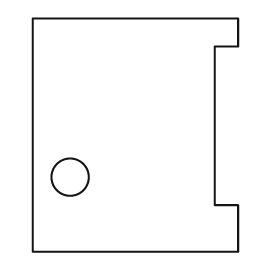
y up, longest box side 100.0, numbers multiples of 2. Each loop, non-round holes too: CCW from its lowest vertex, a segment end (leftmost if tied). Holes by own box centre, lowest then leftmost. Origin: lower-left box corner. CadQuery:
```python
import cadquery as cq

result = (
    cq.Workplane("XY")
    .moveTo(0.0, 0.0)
    .lineTo(88.0, 0.0)
    .lineTo(88.0, 20.0)
    .lineTo(78.0, 20.0)
    .lineTo(78.0, 88.0)
    .lineTo(88.0, 88.0)
    .lineTo(88.0, 100.0)
    .lineTo(0.0, 100.0)
    .close()
    .moveTo(16.0, 32.0)
    .circle(8.0)
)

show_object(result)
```